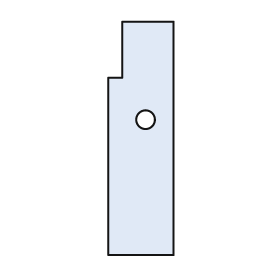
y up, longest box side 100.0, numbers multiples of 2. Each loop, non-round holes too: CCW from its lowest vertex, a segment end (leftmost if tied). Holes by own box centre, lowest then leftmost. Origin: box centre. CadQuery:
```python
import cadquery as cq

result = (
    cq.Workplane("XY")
    .moveTo(-14.0, -50.0)
    .lineTo(14.0, -50.0)
    .lineTo(14.0, 50.0)
    .lineTo(-8.0, 50.0)
    .lineTo(-8.0, 26.0)
    .lineTo(-14.0, 26.0)
    .close()
    .moveTo(2.0, 8.0)
    .circle(4.0)
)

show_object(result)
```